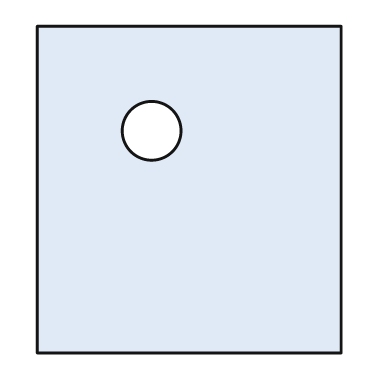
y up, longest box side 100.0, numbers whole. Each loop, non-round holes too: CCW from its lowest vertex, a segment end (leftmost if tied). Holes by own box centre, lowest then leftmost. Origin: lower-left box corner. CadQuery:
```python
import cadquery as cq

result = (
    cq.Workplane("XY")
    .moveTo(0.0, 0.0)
    .lineTo(93.0, 0.0)
    .lineTo(93.0, 100.0)
    .lineTo(0.0, 100.0)
    .close()
    .moveTo(35.0, 68.0)
    .circle(9.0)
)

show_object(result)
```